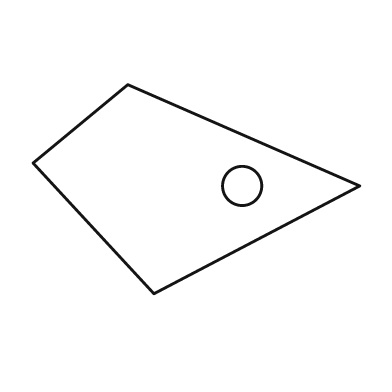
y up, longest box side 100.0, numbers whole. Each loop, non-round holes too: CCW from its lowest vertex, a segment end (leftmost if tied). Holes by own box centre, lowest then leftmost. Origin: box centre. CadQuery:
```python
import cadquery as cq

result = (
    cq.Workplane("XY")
    .moveTo(-13.0, -32.0)
    .lineTo(50.0, 1.0)
    .lineTo(-21.0, 32.0)
    .lineTo(-50.0, 8.0)
    .close()
    .moveTo(14.0, 1.0)
    .circle(6.0)
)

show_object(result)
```